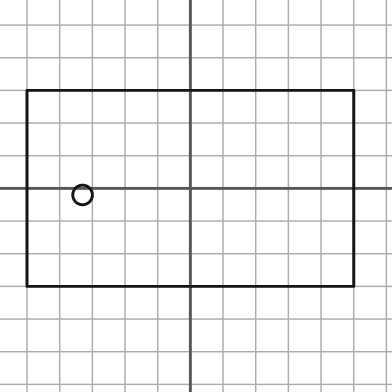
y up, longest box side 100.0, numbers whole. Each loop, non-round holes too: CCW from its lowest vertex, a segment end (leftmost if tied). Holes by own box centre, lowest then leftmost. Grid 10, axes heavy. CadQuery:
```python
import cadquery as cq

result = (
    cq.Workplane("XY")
    .moveTo(-50.0, -30.0)
    .lineTo(50.0, -30.0)
    .lineTo(50.0, 30.0)
    .lineTo(-50.0, 30.0)
    .close()
    .moveTo(-33.0, -2.0)
    .circle(3.0)
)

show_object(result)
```